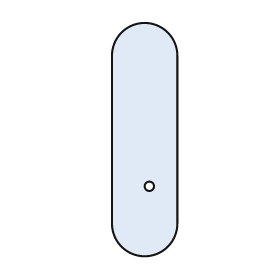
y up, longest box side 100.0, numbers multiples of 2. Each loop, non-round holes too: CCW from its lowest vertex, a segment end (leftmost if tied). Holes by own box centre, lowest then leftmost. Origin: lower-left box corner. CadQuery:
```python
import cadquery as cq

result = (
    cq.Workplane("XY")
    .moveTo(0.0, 14.0)
    .threePointArc((14.0, 0.0), (28.0, 14.0))
    .lineTo(28.0, 86.0)
    .threePointArc((14.0, 100.0), (0.0, 86.0))
    .close()
    .moveTo(16.0, 30.0)
    .circle(2.0)
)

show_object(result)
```